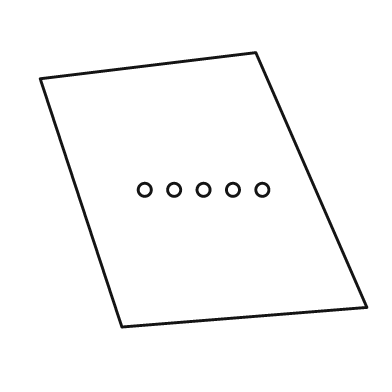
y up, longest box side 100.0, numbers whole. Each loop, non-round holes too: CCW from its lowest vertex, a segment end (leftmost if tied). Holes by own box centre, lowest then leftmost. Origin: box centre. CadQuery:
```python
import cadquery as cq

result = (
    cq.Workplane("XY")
    .moveTo(-25.0, -42.0)
    .lineTo(50.0, -36.0)
    .lineTo(16.0, 42.0)
    .lineTo(-50.0, 34.0)
    .close()
    .moveTo(-18.0, 0.0)
    .circle(2.0)
    .moveTo(-9.0, 0.0)
    .circle(2.0)
    .moveTo(0.0, 0.0)
    .circle(2.0)
    .moveTo(9.0, 0.0)
    .circle(2.0)
    .moveTo(18.0, 0.0)
    .circle(2.0)
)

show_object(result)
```